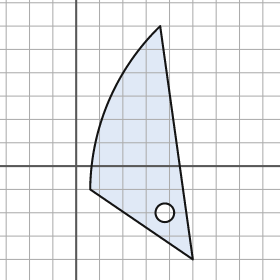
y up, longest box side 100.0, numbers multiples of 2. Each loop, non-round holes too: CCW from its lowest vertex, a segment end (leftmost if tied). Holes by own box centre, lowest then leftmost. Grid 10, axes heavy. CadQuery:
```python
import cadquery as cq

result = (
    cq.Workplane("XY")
    .moveTo(50.0, -40.0)
    .lineTo(36.0, 60.0)
    .threePointArc((14.0, 28.0), (6.0, -10.0))
    .close()
    .moveTo(38.0, -20.0)
    .circle(4.0)
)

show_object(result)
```